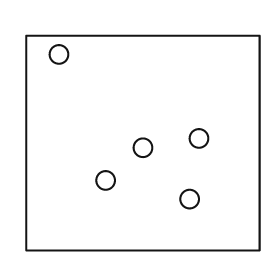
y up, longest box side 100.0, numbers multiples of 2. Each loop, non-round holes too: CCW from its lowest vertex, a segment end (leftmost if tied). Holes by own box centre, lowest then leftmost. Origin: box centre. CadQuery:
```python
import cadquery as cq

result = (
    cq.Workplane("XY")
    .moveTo(-50.0, -46.0)
    .lineTo(50.0, -46.0)
    .lineTo(50.0, 46.0)
    .lineTo(-50.0, 46.0)
    .close()
    .moveTo(20.0, -24.0)
    .circle(4.0)
    .moveTo(-16.0, -16.0)
    .circle(4.0)
    .moveTo(0.0, -2.0)
    .circle(4.0)
    .moveTo(24.0, 2.0)
    .circle(4.0)
    .moveTo(-36.0, 38.0)
    .circle(4.0)
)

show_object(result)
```